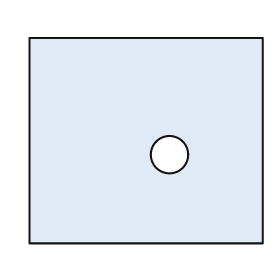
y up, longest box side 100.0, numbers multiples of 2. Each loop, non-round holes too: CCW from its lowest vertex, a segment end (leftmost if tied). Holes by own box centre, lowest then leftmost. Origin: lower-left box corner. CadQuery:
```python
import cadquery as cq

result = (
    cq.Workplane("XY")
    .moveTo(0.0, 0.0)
    .lineTo(100.0, 0.0)
    .lineTo(100.0, 88.0)
    .lineTo(0.0, 88.0)
    .close()
    .moveTo(60.0, 38.0)
    .circle(8.0)
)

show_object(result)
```